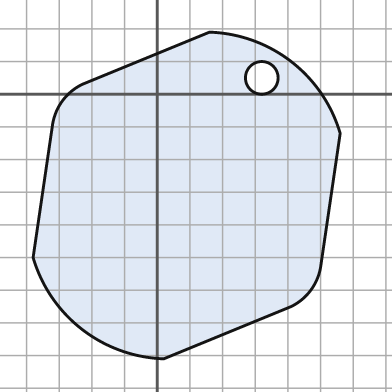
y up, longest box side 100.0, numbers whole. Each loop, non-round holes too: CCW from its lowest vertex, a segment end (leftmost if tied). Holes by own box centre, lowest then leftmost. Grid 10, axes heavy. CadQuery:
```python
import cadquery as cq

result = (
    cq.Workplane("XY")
    .moveTo(2.0, -81.0)
    .lineTo(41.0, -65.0)
    .threePointArc((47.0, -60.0), (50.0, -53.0))
    .lineTo(56.0, -12.0)
    .threePointArc((41.0, 10.0), (16.0, 19.0))
    .lineTo(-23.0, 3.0)
    .threePointArc((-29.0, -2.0), (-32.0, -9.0))
    .lineTo(-38.0, -50.0)
    .threePointArc((-23.0, -72.0), (2.0, -81.0))
    .close()
    .moveTo(32.0, 5.0)
    .circle(5.0)
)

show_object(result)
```